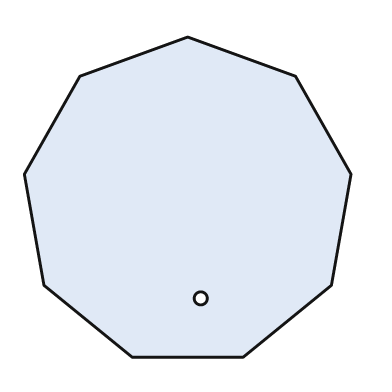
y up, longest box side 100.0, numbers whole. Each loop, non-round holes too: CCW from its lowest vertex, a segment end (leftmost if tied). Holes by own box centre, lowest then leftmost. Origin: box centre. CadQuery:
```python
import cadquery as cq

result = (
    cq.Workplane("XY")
    .moveTo(-17.0, -49.0)
    .lineTo(17.0, -49.0)
    .lineTo(44.0, -27.0)
    .lineTo(50.0, 7.0)
    .lineTo(33.0, 37.0)
    .lineTo(0.0, 49.0)
    .lineTo(-33.0, 37.0)
    .lineTo(-50.0, 7.0)
    .lineTo(-44.0, -27.0)
    .close()
    .moveTo(4.0, -31.0)
    .circle(2.0)
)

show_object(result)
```